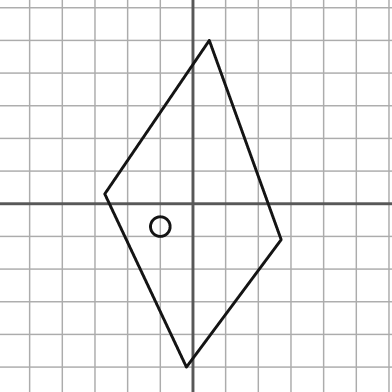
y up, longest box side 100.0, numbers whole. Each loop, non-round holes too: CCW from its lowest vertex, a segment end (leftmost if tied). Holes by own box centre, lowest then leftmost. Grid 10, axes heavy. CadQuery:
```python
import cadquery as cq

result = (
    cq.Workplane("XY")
    .moveTo(-2.0, -50.0)
    .lineTo(27.0, -11.0)
    .lineTo(5.0, 50.0)
    .lineTo(-27.0, 3.0)
    .close()
    .moveTo(-10.0, -7.0)
    .circle(3.0)
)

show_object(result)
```